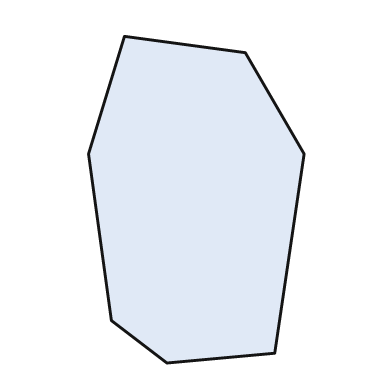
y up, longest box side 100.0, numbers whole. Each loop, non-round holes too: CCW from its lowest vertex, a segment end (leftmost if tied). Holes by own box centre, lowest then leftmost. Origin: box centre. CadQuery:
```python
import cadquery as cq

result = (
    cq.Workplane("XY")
    .moveTo(-9.0, -50.0)
    .lineTo(24.0, -47.0)
    .lineTo(33.0, 14.0)
    .lineTo(15.0, 45.0)
    .lineTo(-22.0, 50.0)
    .lineTo(-33.0, 14.0)
    .lineTo(-26.0, -37.0)
    .close()
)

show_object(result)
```